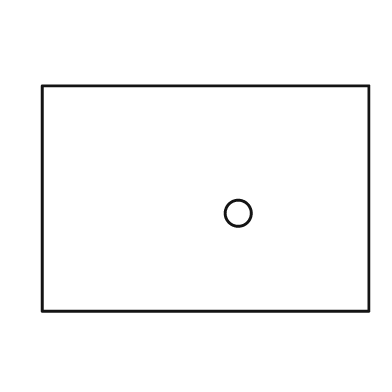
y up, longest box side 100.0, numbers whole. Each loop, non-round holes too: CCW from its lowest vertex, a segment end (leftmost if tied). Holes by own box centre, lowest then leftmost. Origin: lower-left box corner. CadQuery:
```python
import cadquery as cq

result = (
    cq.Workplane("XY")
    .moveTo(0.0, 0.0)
    .lineTo(100.0, 0.0)
    .lineTo(100.0, 69.0)
    .lineTo(0.0, 69.0)
    .close()
    .moveTo(60.0, 30.0)
    .circle(4.0)
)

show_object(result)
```